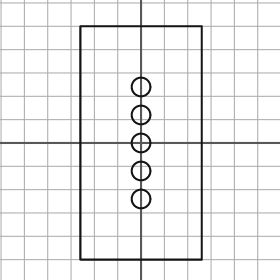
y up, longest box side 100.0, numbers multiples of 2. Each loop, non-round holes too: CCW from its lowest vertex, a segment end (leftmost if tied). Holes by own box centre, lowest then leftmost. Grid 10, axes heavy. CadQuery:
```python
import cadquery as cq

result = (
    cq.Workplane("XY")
    .moveTo(-26.0, -50.0)
    .lineTo(26.0, -50.0)
    .lineTo(26.0, 50.0)
    .lineTo(-26.0, 50.0)
    .close()
    .moveTo(0.0, -24.0)
    .circle(4.0)
    .moveTo(0.0, -12.0)
    .circle(4.0)
    .moveTo(0.0, 0.0)
    .circle(4.0)
    .moveTo(0.0, 12.0)
    .circle(4.0)
    .moveTo(0.0, 24.0)
    .circle(4.0)
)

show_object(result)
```